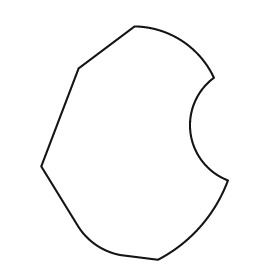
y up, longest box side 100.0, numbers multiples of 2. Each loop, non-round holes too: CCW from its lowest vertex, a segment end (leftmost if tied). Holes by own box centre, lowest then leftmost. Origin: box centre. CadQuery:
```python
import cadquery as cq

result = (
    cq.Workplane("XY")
    .moveTo(10.0, -50.0)
    .threePointArc((28.0, -36.0), (40.0, -16.0))
    .threePointArc((24.0, 4.0), (34.0, 28.0))
    .threePointArc((20.0, 44.0), (0.0, 50.0))
    .lineTo(-24.0, 32.0)
    .lineTo(-40.0, -10.0)
    .lineTo(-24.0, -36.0)
    .threePointArc((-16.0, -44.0), (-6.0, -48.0))
    .close()
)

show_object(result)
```